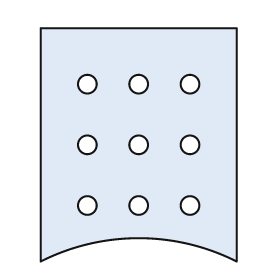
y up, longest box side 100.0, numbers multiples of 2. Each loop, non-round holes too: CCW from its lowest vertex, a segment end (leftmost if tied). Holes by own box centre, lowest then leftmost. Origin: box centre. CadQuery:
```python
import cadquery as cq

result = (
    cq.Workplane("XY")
    .moveTo(-42.0, -50.0)
    .threePointArc((0.0, -40.0), (42.0, -50.0))
    .lineTo(42.0, 50.0)
    .lineTo(-42.0, 50.0)
    .close()
    .moveTo(-22.0, -26.0)
    .circle(4.0)
    .moveTo(0.0, -26.0)
    .circle(4.0)
    .moveTo(22.0, -26.0)
    .circle(4.0)
    .moveTo(-22.0, 0.0)
    .circle(4.0)
    .moveTo(0.0, 0.0)
    .circle(4.0)
    .moveTo(22.0, 0.0)
    .circle(4.0)
    .moveTo(-22.0, 26.0)
    .circle(4.0)
    .moveTo(0.0, 26.0)
    .circle(4.0)
    .moveTo(22.0, 26.0)
    .circle(4.0)
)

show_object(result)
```